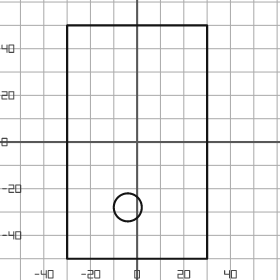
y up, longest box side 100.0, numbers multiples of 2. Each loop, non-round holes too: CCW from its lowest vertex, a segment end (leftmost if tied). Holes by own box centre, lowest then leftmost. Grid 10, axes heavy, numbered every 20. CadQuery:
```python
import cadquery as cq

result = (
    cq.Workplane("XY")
    .moveTo(-30.0, -50.0)
    .lineTo(30.0, -50.0)
    .lineTo(30.0, 50.0)
    .lineTo(-30.0, 50.0)
    .close()
    .moveTo(-4.0, -28.0)
    .circle(6.0)
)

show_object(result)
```